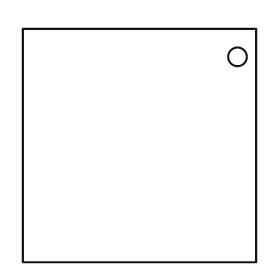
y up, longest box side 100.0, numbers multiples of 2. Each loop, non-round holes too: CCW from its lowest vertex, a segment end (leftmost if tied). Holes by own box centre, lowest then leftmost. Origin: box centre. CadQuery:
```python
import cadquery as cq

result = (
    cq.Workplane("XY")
    .moveTo(-50.0, -50.0)
    .lineTo(50.0, -50.0)
    .lineTo(50.0, 50.0)
    .lineTo(-50.0, 50.0)
    .close()
    .moveTo(42.0, 38.0)
    .circle(4.0)
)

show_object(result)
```